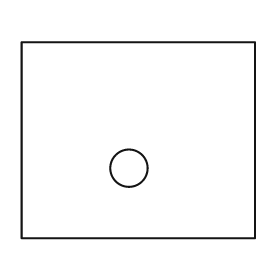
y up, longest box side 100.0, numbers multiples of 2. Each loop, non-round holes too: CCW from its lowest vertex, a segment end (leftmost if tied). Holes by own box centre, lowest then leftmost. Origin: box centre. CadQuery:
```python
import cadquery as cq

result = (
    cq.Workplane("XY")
    .moveTo(-50.0, -42.0)
    .lineTo(50.0, -42.0)
    .lineTo(50.0, 42.0)
    .lineTo(-50.0, 42.0)
    .close()
    .moveTo(-4.0, -12.0)
    .circle(8.0)
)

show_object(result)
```